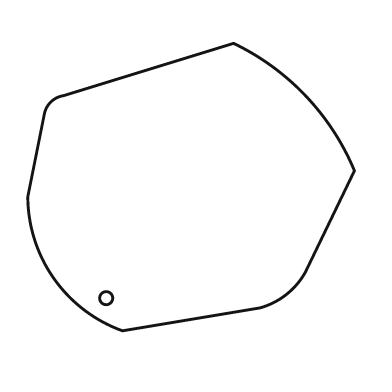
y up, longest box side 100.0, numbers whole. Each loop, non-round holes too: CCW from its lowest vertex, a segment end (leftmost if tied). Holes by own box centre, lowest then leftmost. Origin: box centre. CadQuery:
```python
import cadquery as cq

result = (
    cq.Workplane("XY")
    .moveTo(-21.0, -44.0)
    .lineTo(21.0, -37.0)
    .threePointArc((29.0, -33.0), (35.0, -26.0))
    .lineTo(50.0, 5.0)
    .threePointArc((35.0, 28.0), (13.0, 44.0))
    .lineTo(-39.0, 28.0)
    .threePointArc((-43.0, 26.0), (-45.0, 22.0))
    .lineTo(-50.0, -3.0)
    .threePointArc((-42.0, -28.0), (-21.0, -44.0))
    .close()
    .moveTo(-26.0, -34.0)
    .circle(2.0)
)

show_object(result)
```